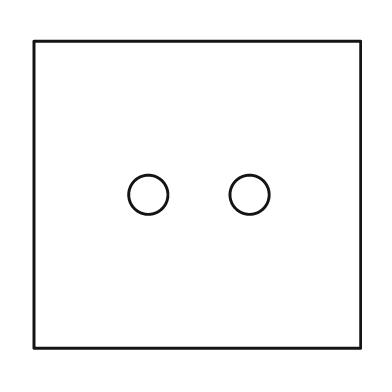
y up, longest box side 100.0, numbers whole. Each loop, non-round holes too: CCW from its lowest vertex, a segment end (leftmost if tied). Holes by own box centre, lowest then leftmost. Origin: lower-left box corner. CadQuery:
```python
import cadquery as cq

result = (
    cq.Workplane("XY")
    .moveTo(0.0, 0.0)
    .lineTo(100.0, 0.0)
    .lineTo(100.0, 94.0)
    .lineTo(0.0, 94.0)
    .close()
    .moveTo(35.0, 47.0)
    .circle(6.0)
    .moveTo(66.0, 47.0)
    .circle(6.0)
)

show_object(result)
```